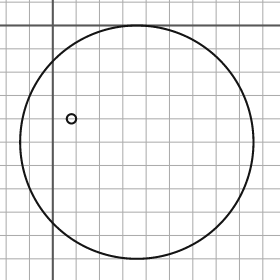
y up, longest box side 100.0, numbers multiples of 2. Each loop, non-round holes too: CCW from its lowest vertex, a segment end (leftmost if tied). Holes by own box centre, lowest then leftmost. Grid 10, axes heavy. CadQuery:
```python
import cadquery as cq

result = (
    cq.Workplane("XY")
    .moveTo(36.0, -50.0)
    .circle(50.0)
    .moveTo(8.0, -40.0)
    .circle(2.0)
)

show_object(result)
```